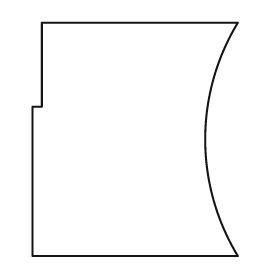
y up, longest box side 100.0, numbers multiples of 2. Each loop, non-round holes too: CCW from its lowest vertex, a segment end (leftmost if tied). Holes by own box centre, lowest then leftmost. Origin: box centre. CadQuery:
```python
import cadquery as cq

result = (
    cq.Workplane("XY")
    .moveTo(-44.0, -50.0)
    .lineTo(44.0, -50.0)
    .threePointArc((30.0, 0.0), (44.0, 50.0))
    .lineTo(-40.0, 50.0)
    .lineTo(-40.0, 14.0)
    .lineTo(-44.0, 14.0)
    .close()
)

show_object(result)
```